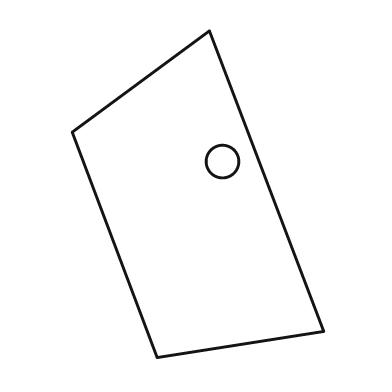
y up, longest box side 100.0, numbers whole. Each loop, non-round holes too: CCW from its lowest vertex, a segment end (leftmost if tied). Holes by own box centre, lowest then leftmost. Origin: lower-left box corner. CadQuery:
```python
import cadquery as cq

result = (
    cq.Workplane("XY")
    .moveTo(26.0, 0.0)
    .lineTo(77.0, 8.0)
    .lineTo(42.0, 100.0)
    .lineTo(0.0, 69.0)
    .close()
    .moveTo(46.0, 60.0)
    .circle(5.0)
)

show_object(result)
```